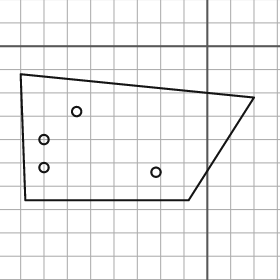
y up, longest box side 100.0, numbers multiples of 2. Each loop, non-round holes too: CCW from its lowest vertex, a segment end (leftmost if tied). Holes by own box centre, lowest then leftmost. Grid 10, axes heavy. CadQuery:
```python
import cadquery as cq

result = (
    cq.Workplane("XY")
    .moveTo(-78.0, -66.0)
    .lineTo(-8.0, -66.0)
    .lineTo(20.0, -22.0)
    .lineTo(-80.0, -12.0)
    .close()
    .moveTo(-22.0, -54.0)
    .circle(2.0)
    .moveTo(-70.0, -52.0)
    .circle(2.0)
    .moveTo(-70.0, -40.0)
    .circle(2.0)
    .moveTo(-56.0, -28.0)
    .circle(2.0)
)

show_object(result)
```